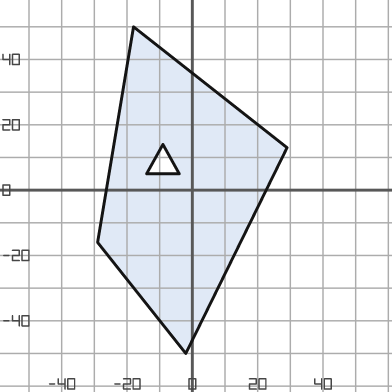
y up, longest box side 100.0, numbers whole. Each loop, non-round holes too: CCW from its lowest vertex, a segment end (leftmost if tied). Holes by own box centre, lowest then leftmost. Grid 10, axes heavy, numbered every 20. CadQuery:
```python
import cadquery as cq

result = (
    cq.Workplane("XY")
    .moveTo(-2.0, -50.0)
    .lineTo(29.0, 13.0)
    .lineTo(-18.0, 50.0)
    .lineTo(-29.0, -16.0)
    .close()
    .moveTo(-14.0, 5.0)
    .lineTo(-4.0, 5.0)
    .lineTo(-9.0, 14.0)
    .close()
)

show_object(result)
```